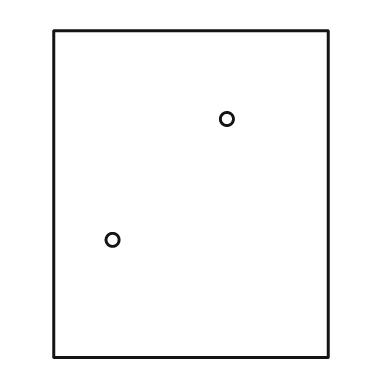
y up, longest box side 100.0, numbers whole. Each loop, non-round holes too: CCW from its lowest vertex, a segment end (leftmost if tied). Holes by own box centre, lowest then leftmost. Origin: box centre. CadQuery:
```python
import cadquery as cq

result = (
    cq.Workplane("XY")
    .moveTo(-42.0, -50.0)
    .lineTo(42.0, -50.0)
    .lineTo(42.0, 50.0)
    .lineTo(-42.0, 50.0)
    .close()
    .moveTo(-24.0, -14.0)
    .circle(2.0)
    .moveTo(11.0, 23.0)
    .circle(2.0)
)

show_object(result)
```